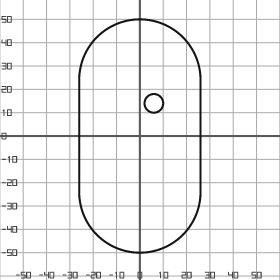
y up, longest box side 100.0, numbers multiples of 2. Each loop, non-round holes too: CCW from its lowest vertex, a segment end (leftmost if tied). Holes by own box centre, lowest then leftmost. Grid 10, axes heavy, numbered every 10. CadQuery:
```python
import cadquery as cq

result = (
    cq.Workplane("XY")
    .moveTo(-26.0, -24.0)
    .threePointArc((0.0, -50.0), (26.0, -24.0))
    .lineTo(26.0, 24.0)
    .threePointArc((0.0, 50.0), (-26.0, 24.0))
    .close()
    .moveTo(6.0, 14.0)
    .circle(4.0)
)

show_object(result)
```